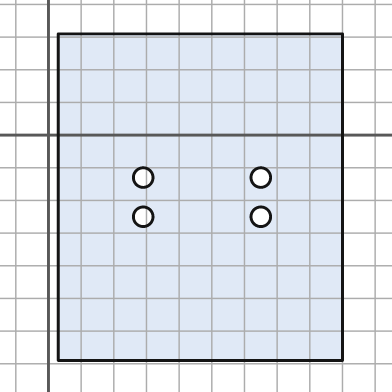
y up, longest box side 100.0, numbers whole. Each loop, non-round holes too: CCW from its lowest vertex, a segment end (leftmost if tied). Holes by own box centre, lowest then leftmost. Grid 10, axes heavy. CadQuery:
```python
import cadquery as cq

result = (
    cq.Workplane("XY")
    .moveTo(3.0, -69.0)
    .lineTo(90.0, -69.0)
    .lineTo(90.0, 31.0)
    .lineTo(3.0, 31.0)
    .close()
    .moveTo(29.0, -25.0)
    .circle(3.0)
    .moveTo(65.0, -25.0)
    .circle(3.0)
    .moveTo(29.0, -13.0)
    .circle(3.0)
    .moveTo(65.0, -13.0)
    .circle(3.0)
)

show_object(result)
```